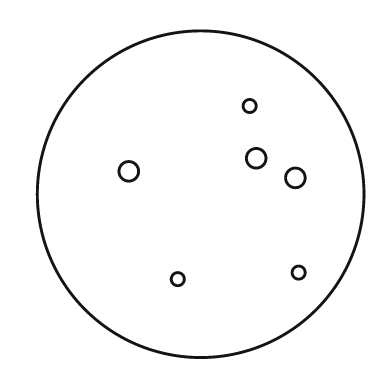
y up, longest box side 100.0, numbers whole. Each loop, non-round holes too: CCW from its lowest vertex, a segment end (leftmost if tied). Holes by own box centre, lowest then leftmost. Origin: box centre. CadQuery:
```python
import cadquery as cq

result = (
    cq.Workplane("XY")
    .moveTo(0.0, 0.0)
    .circle(50.0)
    .moveTo(-7.0, -26.0)
    .circle(2.0)
    .moveTo(30.0, -24.0)
    .circle(2.0)
    .moveTo(29.0, 5.0)
    .circle(3.0)
    .moveTo(-22.0, 7.0)
    .circle(3.0)
    .moveTo(17.0, 11.0)
    .circle(3.0)
    .moveTo(15.0, 27.0)
    .circle(2.0)
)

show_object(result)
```